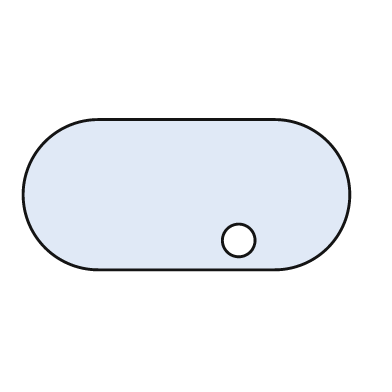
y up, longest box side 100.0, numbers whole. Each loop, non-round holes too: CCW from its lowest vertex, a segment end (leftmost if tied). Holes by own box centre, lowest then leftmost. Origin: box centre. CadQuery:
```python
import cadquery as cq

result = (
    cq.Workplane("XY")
    .moveTo(-27.0, -23.0)
    .lineTo(27.0, -23.0)
    .threePointArc((50.0, 0.0), (27.0, 23.0))
    .lineTo(-27.0, 23.0)
    .threePointArc((-50.0, 0.0), (-27.0, -23.0))
    .close()
    .moveTo(16.0, -14.0)
    .circle(5.0)
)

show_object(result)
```